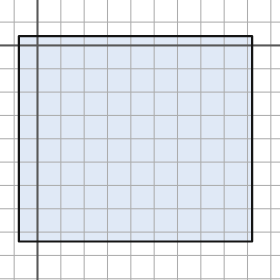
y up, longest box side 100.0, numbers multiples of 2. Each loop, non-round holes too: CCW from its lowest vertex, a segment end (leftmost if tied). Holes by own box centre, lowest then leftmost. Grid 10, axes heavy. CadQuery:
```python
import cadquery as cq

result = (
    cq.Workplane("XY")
    .moveTo(-8.0, -84.0)
    .lineTo(92.0, -84.0)
    .lineTo(92.0, 4.0)
    .lineTo(-8.0, 4.0)
    .close()
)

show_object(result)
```